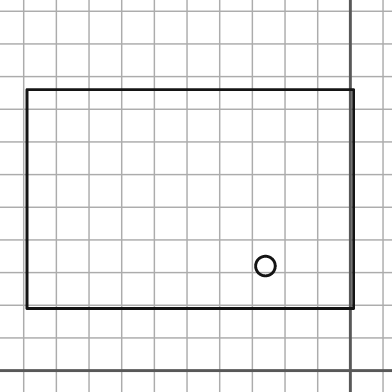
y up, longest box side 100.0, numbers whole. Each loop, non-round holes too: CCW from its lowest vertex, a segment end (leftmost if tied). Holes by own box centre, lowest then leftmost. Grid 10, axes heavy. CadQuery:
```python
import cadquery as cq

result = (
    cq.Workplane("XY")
    .moveTo(-99.0, 19.0)
    .lineTo(1.0, 19.0)
    .lineTo(1.0, 86.0)
    .lineTo(-99.0, 86.0)
    .close()
    .moveTo(-26.0, 32.0)
    .circle(3.0)
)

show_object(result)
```